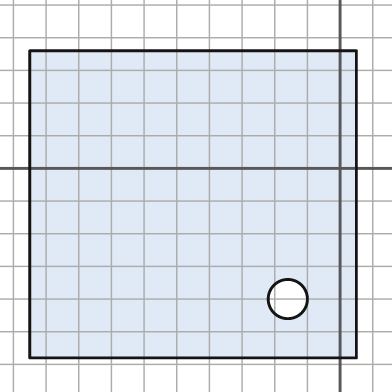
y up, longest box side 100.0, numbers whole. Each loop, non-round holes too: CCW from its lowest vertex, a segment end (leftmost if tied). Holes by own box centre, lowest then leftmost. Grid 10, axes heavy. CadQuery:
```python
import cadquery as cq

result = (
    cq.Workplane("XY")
    .moveTo(-95.0, -58.0)
    .lineTo(5.0, -58.0)
    .lineTo(5.0, 36.0)
    .lineTo(-95.0, 36.0)
    .close()
    .moveTo(-16.0, -40.0)
    .circle(6.0)
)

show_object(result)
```